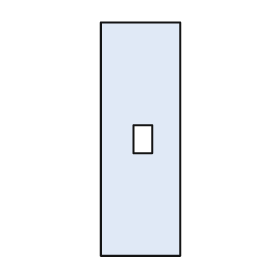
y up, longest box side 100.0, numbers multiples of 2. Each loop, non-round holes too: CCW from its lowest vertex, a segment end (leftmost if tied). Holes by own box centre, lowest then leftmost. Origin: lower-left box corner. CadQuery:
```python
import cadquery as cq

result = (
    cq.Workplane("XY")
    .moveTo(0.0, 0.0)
    .lineTo(34.0, 0.0)
    .lineTo(34.0, 100.0)
    .lineTo(0.0, 100.0)
    .close()
    .moveTo(14.0, 44.0)
    .lineTo(22.0, 44.0)
    .lineTo(22.0, 56.0)
    .lineTo(14.0, 56.0)
    .close()
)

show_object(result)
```